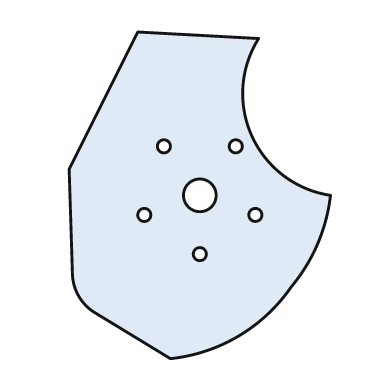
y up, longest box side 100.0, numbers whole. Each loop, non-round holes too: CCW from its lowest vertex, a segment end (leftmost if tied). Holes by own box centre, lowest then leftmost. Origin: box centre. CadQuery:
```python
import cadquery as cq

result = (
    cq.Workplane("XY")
    .moveTo(-9.0, -50.0)
    .threePointArc((12.0, -43.0), (28.0, -28.0))
    .threePointArc((36.0, -15.0), (40.0, 0.0))
    .threePointArc((16.0, 18.0), (18.0, 48.0))
    .lineTo(-19.0, 50.0)
    .lineTo(-40.0, 8.0)
    .lineTo(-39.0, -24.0)
    .threePointArc((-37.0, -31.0), (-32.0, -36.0))
    .close()
    .moveTo(0.0, -18.0)
    .circle(2.0)
    .moveTo(-17.0, -6.0)
    .circle(2.0)
    .moveTo(17.0, -6.0)
    .circle(2.0)
    .moveTo(0.0, 0.0)
    .circle(5.0)
    .moveTo(-11.0, 15.0)
    .circle(2.0)
    .moveTo(11.0, 15.0)
    .circle(2.0)
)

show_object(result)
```